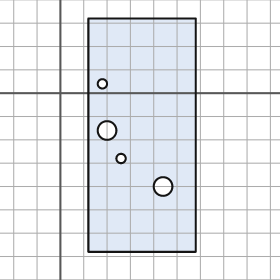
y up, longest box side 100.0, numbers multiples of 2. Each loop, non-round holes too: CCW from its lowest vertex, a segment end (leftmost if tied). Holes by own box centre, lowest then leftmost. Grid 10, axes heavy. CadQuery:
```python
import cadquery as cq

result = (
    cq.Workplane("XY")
    .moveTo(12.0, -68.0)
    .lineTo(58.0, -68.0)
    .lineTo(58.0, 32.0)
    .lineTo(12.0, 32.0)
    .close()
    .moveTo(44.0, -40.0)
    .circle(4.0)
    .moveTo(26.0, -28.0)
    .circle(2.0)
    .moveTo(20.0, -16.0)
    .circle(4.0)
    .moveTo(18.0, 4.0)
    .circle(2.0)
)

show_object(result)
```